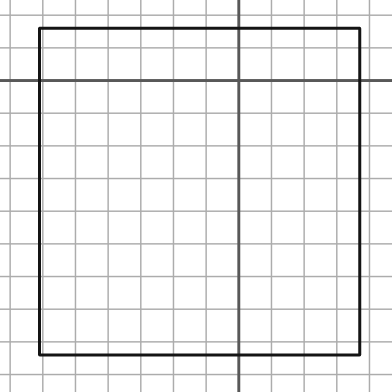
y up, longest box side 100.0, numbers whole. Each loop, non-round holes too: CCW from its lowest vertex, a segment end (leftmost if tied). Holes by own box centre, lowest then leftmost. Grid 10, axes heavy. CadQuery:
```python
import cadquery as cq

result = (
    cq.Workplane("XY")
    .moveTo(-61.0, -84.0)
    .lineTo(37.0, -84.0)
    .lineTo(37.0, 16.0)
    .lineTo(-61.0, 16.0)
    .close()
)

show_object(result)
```